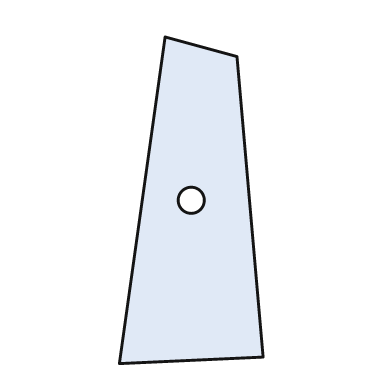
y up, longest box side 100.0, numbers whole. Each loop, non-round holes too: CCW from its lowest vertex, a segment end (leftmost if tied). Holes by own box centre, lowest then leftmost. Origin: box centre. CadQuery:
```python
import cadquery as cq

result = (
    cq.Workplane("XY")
    .moveTo(-22.0, -50.0)
    .lineTo(22.0, -48.0)
    .lineTo(14.0, 44.0)
    .lineTo(-8.0, 50.0)
    .close()
    .moveTo(0.0, 0.0)
    .circle(4.0)
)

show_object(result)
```